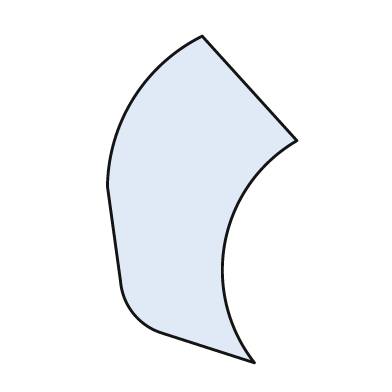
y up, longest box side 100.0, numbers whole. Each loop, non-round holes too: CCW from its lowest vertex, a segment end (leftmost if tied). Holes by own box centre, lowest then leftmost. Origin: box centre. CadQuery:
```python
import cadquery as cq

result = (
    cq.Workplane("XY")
    .moveTo(16.0, -50.0)
    .threePointArc((7.0, -13.0), (29.0, 18.0))
    .lineTo(0.0, 50.0)
    .threePointArc((-21.0, 31.0), (-29.0, 4.0))
    .lineTo(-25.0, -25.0)
    .threePointArc((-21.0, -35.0), (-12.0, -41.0))
    .close()
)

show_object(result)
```